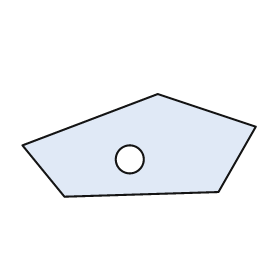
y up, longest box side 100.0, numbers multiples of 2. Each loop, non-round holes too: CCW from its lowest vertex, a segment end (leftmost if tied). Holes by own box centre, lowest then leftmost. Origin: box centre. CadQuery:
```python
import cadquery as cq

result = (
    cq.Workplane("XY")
    .moveTo(-32.0, -22.0)
    .lineTo(34.0, -20.0)
    .lineTo(50.0, 8.0)
    .lineTo(8.0, 22.0)
    .lineTo(-50.0, 0.0)
    .close()
    .moveTo(-4.0, -6.0)
    .circle(6.0)
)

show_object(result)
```